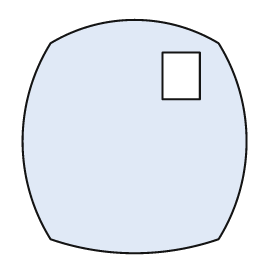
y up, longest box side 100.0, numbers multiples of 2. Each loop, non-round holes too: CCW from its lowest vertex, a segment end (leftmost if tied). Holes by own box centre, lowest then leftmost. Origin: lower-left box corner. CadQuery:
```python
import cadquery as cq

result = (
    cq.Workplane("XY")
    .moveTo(12.0, 6.0)
    .threePointArc((48.0, 0.0), (84.0, 6.0))
    .threePointArc((96.0, 48.0), (84.0, 90.0))
    .threePointArc((48.0, 100.0), (12.0, 90.0))
    .threePointArc((0.0, 48.0), (12.0, 6.0))
    .close()
    .moveTo(60.0, 66.0)
    .lineTo(76.0, 66.0)
    .lineTo(76.0, 86.0)
    .lineTo(60.0, 86.0)
    .close()
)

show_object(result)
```